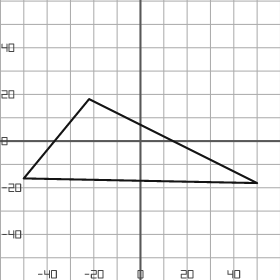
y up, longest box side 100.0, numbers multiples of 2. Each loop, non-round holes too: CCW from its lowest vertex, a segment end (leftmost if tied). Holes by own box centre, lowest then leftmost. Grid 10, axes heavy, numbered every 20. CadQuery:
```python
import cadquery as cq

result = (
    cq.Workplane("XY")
    .moveTo(50.0, -18.0)
    .lineTo(-22.0, 18.0)
    .lineTo(-50.0, -16.0)
    .close()
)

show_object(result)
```